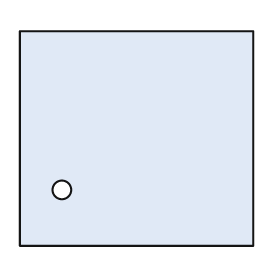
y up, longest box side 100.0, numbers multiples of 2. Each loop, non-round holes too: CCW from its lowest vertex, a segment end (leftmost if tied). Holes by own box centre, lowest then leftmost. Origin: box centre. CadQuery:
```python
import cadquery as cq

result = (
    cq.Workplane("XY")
    .moveTo(-50.0, -46.0)
    .lineTo(50.0, -46.0)
    .lineTo(50.0, 46.0)
    .lineTo(-50.0, 46.0)
    .close()
    .moveTo(-32.0, -22.0)
    .circle(4.0)
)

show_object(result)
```